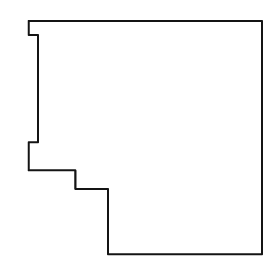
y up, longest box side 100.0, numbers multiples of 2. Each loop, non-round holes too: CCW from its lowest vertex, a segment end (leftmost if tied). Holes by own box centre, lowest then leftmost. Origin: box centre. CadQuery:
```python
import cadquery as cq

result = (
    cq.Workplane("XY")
    .moveTo(-16.0, -50.0)
    .lineTo(50.0, -50.0)
    .lineTo(50.0, 50.0)
    .lineTo(-50.0, 50.0)
    .lineTo(-50.0, 44.0)
    .lineTo(-46.0, 44.0)
    .lineTo(-46.0, -2.0)
    .lineTo(-50.0, -2.0)
    .lineTo(-50.0, -14.0)
    .lineTo(-30.0, -14.0)
    .lineTo(-30.0, -22.0)
    .lineTo(-16.0, -22.0)
    .close()
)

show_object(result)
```